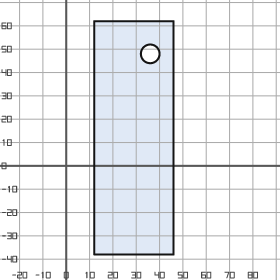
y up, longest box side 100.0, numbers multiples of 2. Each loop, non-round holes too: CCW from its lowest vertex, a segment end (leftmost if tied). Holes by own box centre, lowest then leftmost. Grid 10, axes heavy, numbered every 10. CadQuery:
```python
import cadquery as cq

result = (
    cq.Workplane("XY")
    .moveTo(12.0, -38.0)
    .lineTo(46.0, -38.0)
    .lineTo(46.0, 62.0)
    .lineTo(12.0, 62.0)
    .close()
    .moveTo(36.0, 48.0)
    .circle(4.0)
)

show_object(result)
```